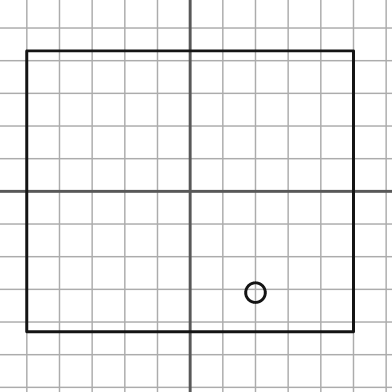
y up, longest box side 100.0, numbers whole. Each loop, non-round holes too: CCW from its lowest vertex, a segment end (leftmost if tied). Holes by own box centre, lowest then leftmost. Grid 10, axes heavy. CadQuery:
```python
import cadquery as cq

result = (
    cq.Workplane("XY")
    .moveTo(-50.0, -43.0)
    .lineTo(50.0, -43.0)
    .lineTo(50.0, 43.0)
    .lineTo(-50.0, 43.0)
    .close()
    .moveTo(20.0, -31.0)
    .circle(3.0)
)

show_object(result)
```